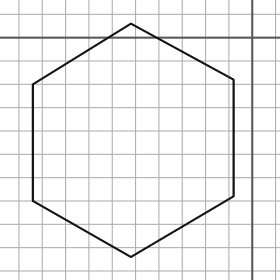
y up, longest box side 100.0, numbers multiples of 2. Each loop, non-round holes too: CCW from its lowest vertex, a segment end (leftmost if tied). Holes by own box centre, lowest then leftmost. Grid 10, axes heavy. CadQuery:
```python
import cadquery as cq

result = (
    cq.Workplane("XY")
    .moveTo(-52.0, -94.0)
    .lineTo(-8.0, -68.0)
    .lineTo(-8.0, -18.0)
    .lineTo(-52.0, 6.0)
    .lineTo(-94.0, -20.0)
    .lineTo(-94.0, -70.0)
    .close()
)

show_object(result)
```